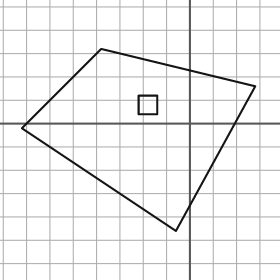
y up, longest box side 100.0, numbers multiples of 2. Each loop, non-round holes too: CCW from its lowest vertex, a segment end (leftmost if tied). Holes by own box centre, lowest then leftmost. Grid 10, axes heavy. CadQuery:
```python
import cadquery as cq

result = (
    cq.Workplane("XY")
    .moveTo(-6.0, -46.0)
    .lineTo(28.0, 16.0)
    .lineTo(-38.0, 32.0)
    .lineTo(-72.0, -2.0)
    .close()
    .moveTo(-22.0, 4.0)
    .lineTo(-14.0, 4.0)
    .lineTo(-14.0, 12.0)
    .lineTo(-22.0, 12.0)
    .close()
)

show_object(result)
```